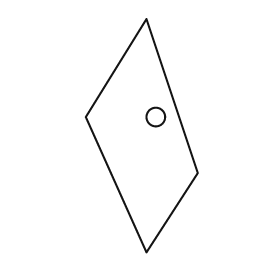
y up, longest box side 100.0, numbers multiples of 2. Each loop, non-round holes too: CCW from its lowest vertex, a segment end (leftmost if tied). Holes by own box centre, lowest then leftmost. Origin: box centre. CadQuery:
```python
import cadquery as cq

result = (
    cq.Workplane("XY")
    .moveTo(2.0, -50.0)
    .lineTo(24.0, -16.0)
    .lineTo(2.0, 50.0)
    .lineTo(-24.0, 8.0)
    .close()
    .moveTo(6.0, 8.0)
    .circle(4.0)
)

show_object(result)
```